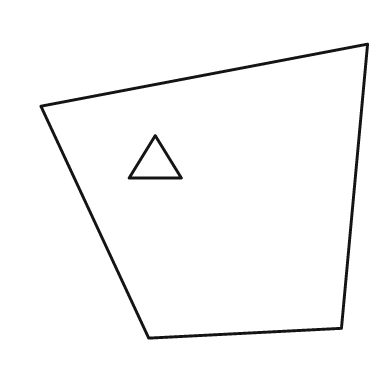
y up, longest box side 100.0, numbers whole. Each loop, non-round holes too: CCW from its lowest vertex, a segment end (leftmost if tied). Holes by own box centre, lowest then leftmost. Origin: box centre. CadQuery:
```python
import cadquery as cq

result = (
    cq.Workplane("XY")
    .moveTo(-17.0, -45.0)
    .lineTo(42.0, -42.0)
    .lineTo(50.0, 45.0)
    .lineTo(-50.0, 26.0)
    .close()
    .moveTo(-23.0, 4.0)
    .lineTo(-7.0, 4.0)
    .lineTo(-15.0, 17.0)
    .close()
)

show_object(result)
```